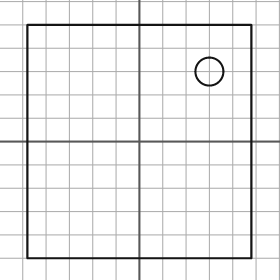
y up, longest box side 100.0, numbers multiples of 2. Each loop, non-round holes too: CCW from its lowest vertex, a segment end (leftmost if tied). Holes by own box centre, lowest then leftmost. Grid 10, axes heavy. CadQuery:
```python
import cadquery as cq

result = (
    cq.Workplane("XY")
    .moveTo(-48.0, -50.0)
    .lineTo(48.0, -50.0)
    .lineTo(48.0, 50.0)
    .lineTo(-48.0, 50.0)
    .close()
    .moveTo(30.0, 30.0)
    .circle(6.0)
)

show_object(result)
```